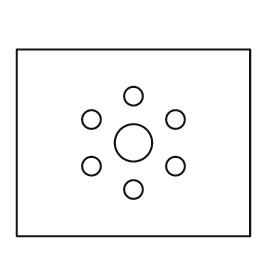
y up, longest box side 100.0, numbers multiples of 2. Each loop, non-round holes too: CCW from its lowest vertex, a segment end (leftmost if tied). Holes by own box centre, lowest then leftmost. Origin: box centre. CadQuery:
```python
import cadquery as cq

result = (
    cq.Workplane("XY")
    .moveTo(-50.0, -40.0)
    .lineTo(50.0, -40.0)
    .lineTo(50.0, 40.0)
    .lineTo(-50.0, 40.0)
    .close()
    .moveTo(0.0, -20.0)
    .circle(4.0)
    .moveTo(-18.0, -10.0)
    .circle(4.0)
    .moveTo(18.0, -10.0)
    .circle(4.0)
    .moveTo(0.0, 0.0)
    .circle(8.0)
    .moveTo(-18.0, 10.0)
    .circle(4.0)
    .moveTo(18.0, 10.0)
    .circle(4.0)
    .moveTo(0.0, 20.0)
    .circle(4.0)
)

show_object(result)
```